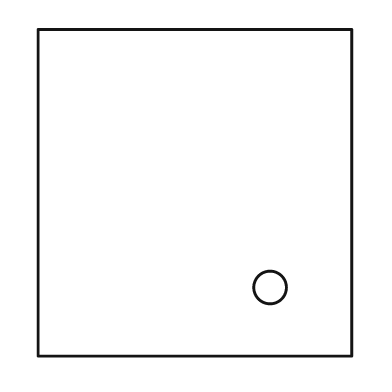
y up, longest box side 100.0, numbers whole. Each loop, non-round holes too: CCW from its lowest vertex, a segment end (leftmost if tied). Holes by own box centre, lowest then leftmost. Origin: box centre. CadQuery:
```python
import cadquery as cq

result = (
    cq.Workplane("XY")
    .moveTo(-48.0, -50.0)
    .lineTo(48.0, -50.0)
    .lineTo(48.0, 50.0)
    .lineTo(-48.0, 50.0)
    .close()
    .moveTo(23.0, -29.0)
    .circle(5.0)
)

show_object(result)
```